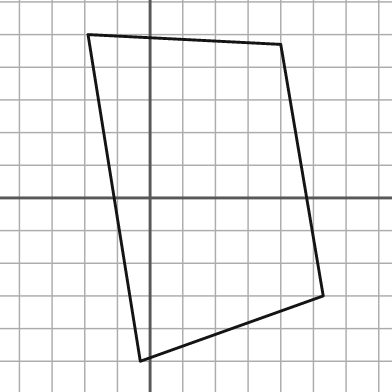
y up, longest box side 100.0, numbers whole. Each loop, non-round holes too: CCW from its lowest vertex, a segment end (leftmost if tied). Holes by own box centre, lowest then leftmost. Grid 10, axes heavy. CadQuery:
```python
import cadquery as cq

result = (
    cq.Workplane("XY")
    .moveTo(-3.0, -50.0)
    .lineTo(53.0, -30.0)
    .lineTo(40.0, 47.0)
    .lineTo(-19.0, 50.0)
    .close()
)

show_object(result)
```